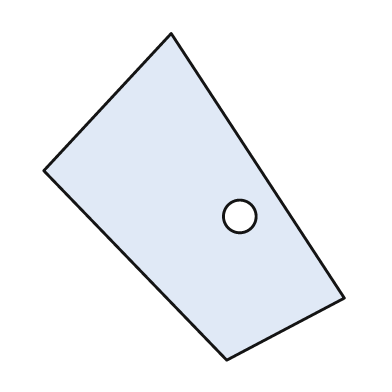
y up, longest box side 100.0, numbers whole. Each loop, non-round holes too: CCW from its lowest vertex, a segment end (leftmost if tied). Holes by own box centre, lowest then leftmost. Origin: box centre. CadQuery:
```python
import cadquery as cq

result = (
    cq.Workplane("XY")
    .moveTo(10.0, -50.0)
    .lineTo(46.0, -31.0)
    .lineTo(-7.0, 50.0)
    .lineTo(-46.0, 8.0)
    .close()
    .moveTo(14.0, -6.0)
    .circle(5.0)
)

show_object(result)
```